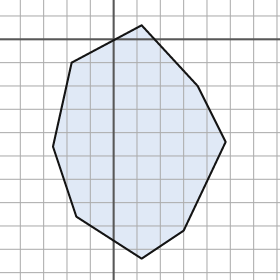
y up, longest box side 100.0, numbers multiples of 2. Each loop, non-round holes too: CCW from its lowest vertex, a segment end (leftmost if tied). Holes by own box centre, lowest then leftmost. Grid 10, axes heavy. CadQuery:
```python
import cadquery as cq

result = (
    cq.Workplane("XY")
    .moveTo(12.0, -94.0)
    .lineTo(30.0, -82.0)
    .lineTo(48.0, -44.0)
    .lineTo(36.0, -20.0)
    .lineTo(12.0, 6.0)
    .lineTo(-18.0, -10.0)
    .lineTo(-26.0, -46.0)
    .lineTo(-16.0, -76.0)
    .close()
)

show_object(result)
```